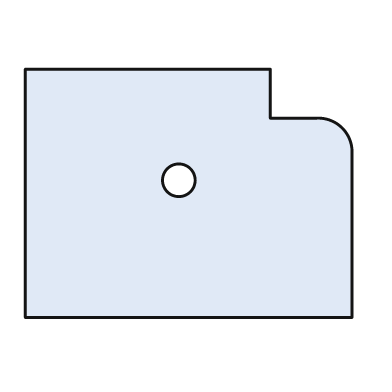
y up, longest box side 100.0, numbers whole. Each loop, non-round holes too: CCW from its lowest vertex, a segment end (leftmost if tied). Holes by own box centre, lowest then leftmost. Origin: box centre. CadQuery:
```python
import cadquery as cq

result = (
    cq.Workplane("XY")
    .moveTo(-50.0, -38.0)
    .lineTo(50.0, -38.0)
    .lineTo(50.0, 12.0)
    .threePointArc((47.0, 20.0), (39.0, 23.0))
    .lineTo(25.0, 23.0)
    .lineTo(25.0, 38.0)
    .lineTo(-50.0, 38.0)
    .close()
    .moveTo(-3.0, 4.0)
    .circle(5.0)
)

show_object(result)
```